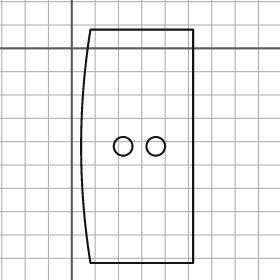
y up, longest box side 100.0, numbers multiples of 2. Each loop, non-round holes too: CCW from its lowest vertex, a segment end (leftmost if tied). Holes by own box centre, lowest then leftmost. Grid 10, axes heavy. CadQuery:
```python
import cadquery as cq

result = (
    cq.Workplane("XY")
    .moveTo(8.0, -92.0)
    .lineTo(52.0, -92.0)
    .lineTo(52.0, 8.0)
    .lineTo(8.0, 8.0)
    .threePointArc((4.0, -42.0), (8.0, -92.0))
    .close()
    .moveTo(22.0, -42.0)
    .circle(4.0)
    .moveTo(36.0, -42.0)
    .circle(4.0)
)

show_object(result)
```